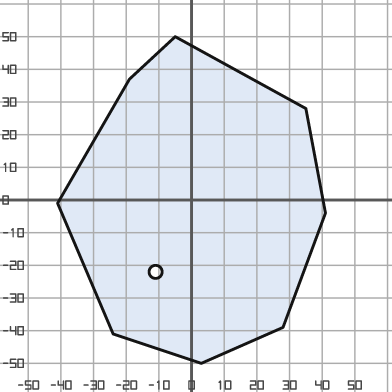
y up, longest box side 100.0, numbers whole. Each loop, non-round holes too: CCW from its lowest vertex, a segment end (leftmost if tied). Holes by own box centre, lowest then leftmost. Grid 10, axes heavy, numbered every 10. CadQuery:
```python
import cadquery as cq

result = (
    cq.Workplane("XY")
    .moveTo(3.0, -50.0)
    .lineTo(28.0, -39.0)
    .lineTo(41.0, -4.0)
    .lineTo(35.0, 28.0)
    .lineTo(-5.0, 50.0)
    .lineTo(-19.0, 37.0)
    .lineTo(-41.0, -1.0)
    .lineTo(-24.0, -41.0)
    .close()
    .moveTo(-11.0, -22.0)
    .circle(2.0)
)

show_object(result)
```